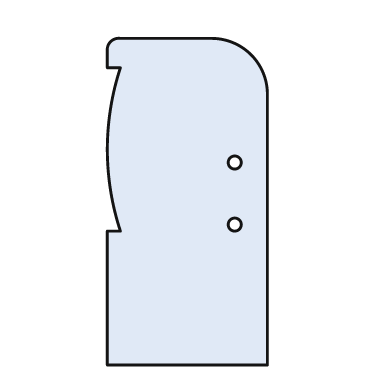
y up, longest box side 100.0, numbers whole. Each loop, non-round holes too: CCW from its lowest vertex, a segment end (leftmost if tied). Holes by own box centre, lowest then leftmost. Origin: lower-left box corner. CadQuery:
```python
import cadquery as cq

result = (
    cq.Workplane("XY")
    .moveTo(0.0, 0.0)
    .lineTo(49.0, 0.0)
    .lineTo(49.0, 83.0)
    .threePointArc((44.0, 95.0), (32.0, 100.0))
    .lineTo(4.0, 100.0)
    .threePointArc((1.0, 99.0), (0.0, 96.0))
    .lineTo(0.0, 91.0)
    .lineTo(4.0, 91.0)
    .threePointArc((0.0, 66.0), (4.0, 41.0))
    .lineTo(0.0, 41.0)
    .close()
    .moveTo(39.0, 43.0)
    .circle(2.0)
    .moveTo(39.0, 62.0)
    .circle(2.0)
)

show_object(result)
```